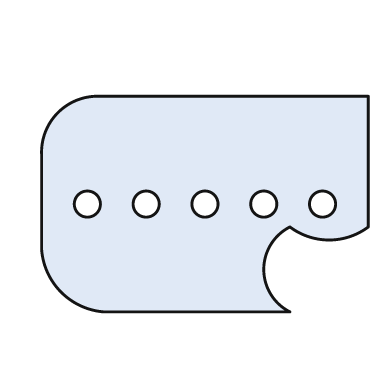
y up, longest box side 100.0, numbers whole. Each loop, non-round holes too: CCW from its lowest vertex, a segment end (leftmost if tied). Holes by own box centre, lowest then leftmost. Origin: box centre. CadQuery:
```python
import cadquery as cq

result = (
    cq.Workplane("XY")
    .moveTo(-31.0, -33.0)
    .lineTo(26.0, -33.0)
    .threePointArc((18.0, -20.0), (26.0, -7.0))
    .threePointArc((38.0, -11.0), (50.0, -7.0))
    .lineTo(50.0, 33.0)
    .lineTo(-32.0, 33.0)
    .threePointArc((-45.0, 28.0), (-50.0, 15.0))
    .lineTo(-50.0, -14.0)
    .threePointArc((-44.0, -27.0), (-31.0, -33.0))
    .close()
    .moveTo(-36.0, 0.0)
    .circle(4.0)
    .moveTo(-18.0, 0.0)
    .circle(4.0)
    .moveTo(0.0, 0.0)
    .circle(4.0)
    .moveTo(18.0, 0.0)
    .circle(4.0)
    .moveTo(36.0, 0.0)
    .circle(4.0)
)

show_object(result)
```